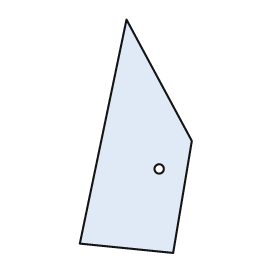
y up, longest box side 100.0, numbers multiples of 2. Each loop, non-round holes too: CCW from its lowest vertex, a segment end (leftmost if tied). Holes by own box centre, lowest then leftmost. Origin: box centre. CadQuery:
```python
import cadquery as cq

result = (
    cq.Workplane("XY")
    .moveTo(16.0, -50.0)
    .lineTo(24.0, -2.0)
    .lineTo(-4.0, 50.0)
    .lineTo(-24.0, -46.0)
    .close()
    .moveTo(10.0, -14.0)
    .circle(2.0)
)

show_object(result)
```